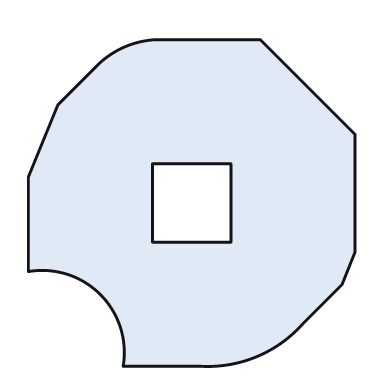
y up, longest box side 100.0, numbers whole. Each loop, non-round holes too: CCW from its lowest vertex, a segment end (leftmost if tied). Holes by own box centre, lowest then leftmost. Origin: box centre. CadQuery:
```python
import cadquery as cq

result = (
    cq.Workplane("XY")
    .moveTo(-21.0, -50.0)
    .lineTo(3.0, -50.0)
    .threePointArc((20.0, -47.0), (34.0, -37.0))
    .lineTo(46.0, -25.0)
    .lineTo(50.0, -15.0)
    .lineTo(50.0, 21.0)
    .lineTo(21.0, 50.0)
    .lineTo(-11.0, 50.0)
    .threePointArc((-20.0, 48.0), (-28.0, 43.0))
    .lineTo(-41.0, 30.0)
    .lineTo(-50.0, 8.0)
    .lineTo(-50.0, -21.0)
    .threePointArc((-28.0, -28.0), (-21.0, -50.0))
    .close()
    .moveTo(-12.0, -12.0)
    .lineTo(12.0, -12.0)
    .lineTo(12.0, 12.0)
    .lineTo(-12.0, 12.0)
    .close()
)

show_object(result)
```